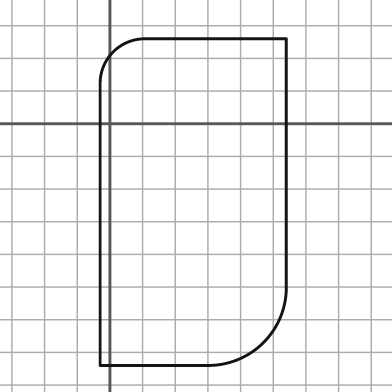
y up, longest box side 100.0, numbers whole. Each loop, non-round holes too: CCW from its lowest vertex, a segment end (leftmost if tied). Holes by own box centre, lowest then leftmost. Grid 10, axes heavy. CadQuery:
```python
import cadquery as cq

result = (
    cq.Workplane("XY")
    .moveTo(-3.0, -74.0)
    .lineTo(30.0, -74.0)
    .threePointArc((47.0, -67.0), (54.0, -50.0))
    .lineTo(54.0, 26.0)
    .lineTo(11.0, 26.0)
    .threePointArc((1.0, 22.0), (-3.0, 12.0))
    .close()
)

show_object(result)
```